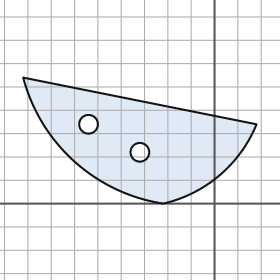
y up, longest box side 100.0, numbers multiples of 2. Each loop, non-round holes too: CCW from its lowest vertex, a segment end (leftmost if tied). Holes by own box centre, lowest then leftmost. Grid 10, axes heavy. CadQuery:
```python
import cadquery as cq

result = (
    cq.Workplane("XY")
    .moveTo(-22.0, 0.0)
    .threePointArc((2.0, 12.0), (18.0, 34.0))
    .lineTo(-82.0, 54.0)
    .threePointArc((-60.0, 18.0), (-22.0, 0.0))
    .close()
    .moveTo(-32.0, 22.0)
    .circle(4.0)
    .moveTo(-54.0, 34.0)
    .circle(4.0)
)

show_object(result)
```